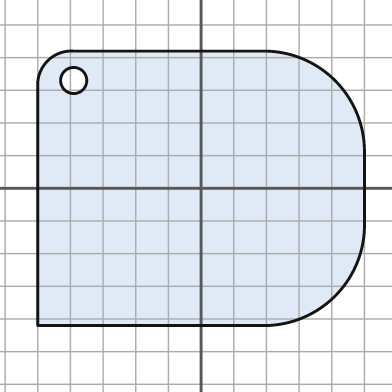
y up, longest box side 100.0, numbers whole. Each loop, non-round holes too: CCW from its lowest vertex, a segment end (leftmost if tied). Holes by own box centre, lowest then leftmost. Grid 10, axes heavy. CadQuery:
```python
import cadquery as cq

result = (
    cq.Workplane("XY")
    .moveTo(-50.0, -42.0)
    .lineTo(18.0, -42.0)
    .threePointArc((41.0, -33.0), (50.0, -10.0))
    .lineTo(50.0, 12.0)
    .threePointArc((41.0, 33.0), (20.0, 42.0))
    .lineTo(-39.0, 42.0)
    .threePointArc((-47.0, 39.0), (-50.0, 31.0))
    .close()
    .moveTo(-39.0, 33.0)
    .circle(4.0)
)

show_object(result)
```